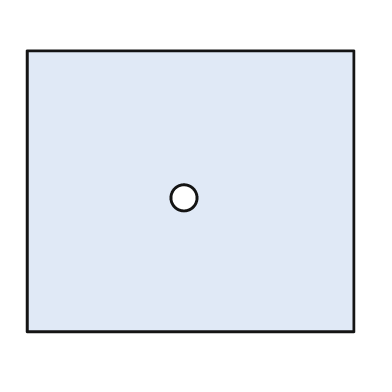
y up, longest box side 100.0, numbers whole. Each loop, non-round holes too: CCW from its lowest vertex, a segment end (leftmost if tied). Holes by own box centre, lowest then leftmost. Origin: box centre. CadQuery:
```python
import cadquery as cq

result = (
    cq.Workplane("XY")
    .moveTo(-50.0, -43.0)
    .lineTo(50.0, -43.0)
    .lineTo(50.0, 43.0)
    .lineTo(-50.0, 43.0)
    .close()
    .moveTo(-2.0, -2.0)
    .circle(4.0)
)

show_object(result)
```